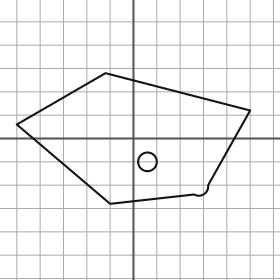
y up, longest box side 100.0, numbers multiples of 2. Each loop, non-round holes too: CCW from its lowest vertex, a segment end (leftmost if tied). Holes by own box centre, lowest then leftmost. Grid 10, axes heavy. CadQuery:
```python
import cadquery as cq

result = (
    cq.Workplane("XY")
    .moveTo(-10.0, -28.0)
    .lineTo(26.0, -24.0)
    .threePointArc((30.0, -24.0), (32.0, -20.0))
    .lineTo(50.0, 12.0)
    .lineTo(-12.0, 28.0)
    .lineTo(-50.0, 6.0)
    .close()
    .moveTo(6.0, -10.0)
    .circle(4.0)
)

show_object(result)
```